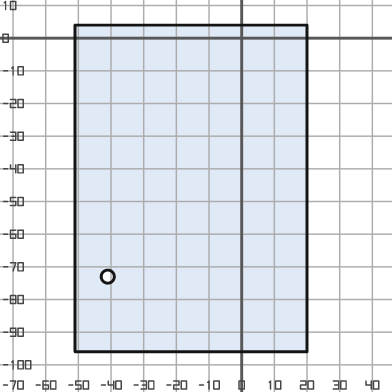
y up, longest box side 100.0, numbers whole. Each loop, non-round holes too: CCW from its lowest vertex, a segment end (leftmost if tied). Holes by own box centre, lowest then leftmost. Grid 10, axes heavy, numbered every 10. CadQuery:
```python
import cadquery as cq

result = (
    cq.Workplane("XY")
    .moveTo(-51.0, -96.0)
    .lineTo(20.0, -96.0)
    .lineTo(20.0, 4.0)
    .lineTo(-51.0, 4.0)
    .close()
    .moveTo(-41.0, -73.0)
    .circle(2.0)
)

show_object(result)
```